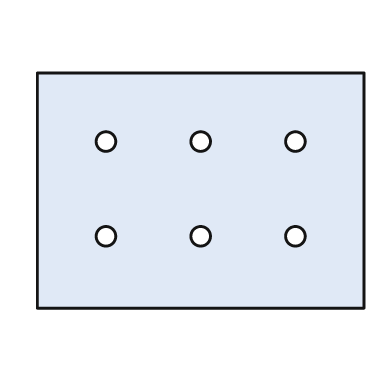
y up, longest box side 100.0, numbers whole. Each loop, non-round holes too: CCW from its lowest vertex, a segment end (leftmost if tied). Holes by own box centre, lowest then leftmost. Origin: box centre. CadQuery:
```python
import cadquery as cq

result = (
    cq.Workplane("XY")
    .moveTo(-50.0, -36.0)
    .lineTo(50.0, -36.0)
    .lineTo(50.0, 36.0)
    .lineTo(-50.0, 36.0)
    .close()
    .moveTo(-29.0, -14.0)
    .circle(3.0)
    .moveTo(0.0, -14.0)
    .circle(3.0)
    .moveTo(29.0, -14.0)
    .circle(3.0)
    .moveTo(-29.0, 15.0)
    .circle(3.0)
    .moveTo(0.0, 15.0)
    .circle(3.0)
    .moveTo(29.0, 15.0)
    .circle(3.0)
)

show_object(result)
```